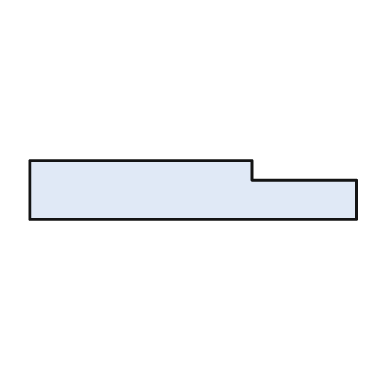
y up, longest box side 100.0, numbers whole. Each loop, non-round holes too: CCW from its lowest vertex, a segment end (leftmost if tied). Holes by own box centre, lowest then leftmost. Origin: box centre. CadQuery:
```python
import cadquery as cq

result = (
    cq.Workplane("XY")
    .moveTo(-50.0, -9.0)
    .lineTo(50.0, -9.0)
    .lineTo(50.0, 3.0)
    .lineTo(18.0, 3.0)
    .lineTo(18.0, 9.0)
    .lineTo(-50.0, 9.0)
    .close()
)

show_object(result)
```